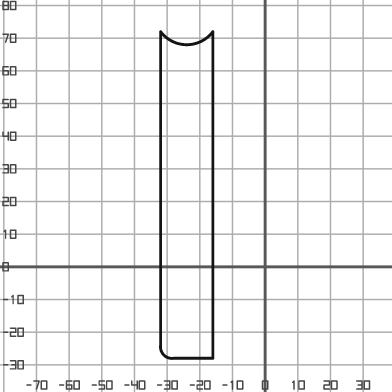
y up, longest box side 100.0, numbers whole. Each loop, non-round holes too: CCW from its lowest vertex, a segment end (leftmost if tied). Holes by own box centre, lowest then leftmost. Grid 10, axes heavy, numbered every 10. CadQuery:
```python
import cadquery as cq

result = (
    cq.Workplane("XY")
    .moveTo(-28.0, -28.0)
    .lineTo(-16.0, -28.0)
    .lineTo(-16.0, 72.0)
    .threePointArc((-24.0, 68.0), (-32.0, 72.0))
    .lineTo(-32.0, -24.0)
    .threePointArc((-31.0, -27.0), (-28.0, -28.0))
    .close()
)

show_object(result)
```